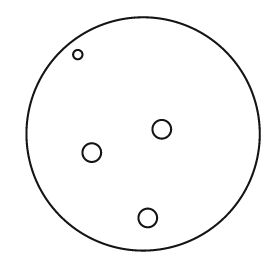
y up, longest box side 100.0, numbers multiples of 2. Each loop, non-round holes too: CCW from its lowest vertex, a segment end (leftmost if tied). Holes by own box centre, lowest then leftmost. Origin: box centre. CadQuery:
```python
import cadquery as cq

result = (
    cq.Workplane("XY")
    .moveTo(0.0, 0.0)
    .circle(50.0)
    .moveTo(2.0, -36.0)
    .circle(4.0)
    .moveTo(-22.0, -8.0)
    .circle(4.0)
    .moveTo(8.0, 2.0)
    .circle(4.0)
    .moveTo(-28.0, 34.0)
    .circle(2.0)
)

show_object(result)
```